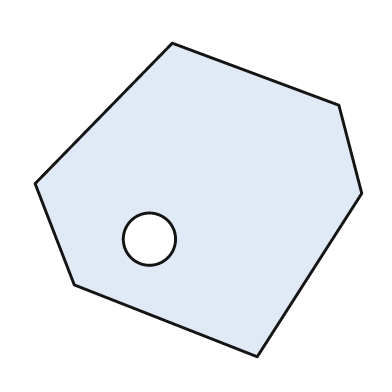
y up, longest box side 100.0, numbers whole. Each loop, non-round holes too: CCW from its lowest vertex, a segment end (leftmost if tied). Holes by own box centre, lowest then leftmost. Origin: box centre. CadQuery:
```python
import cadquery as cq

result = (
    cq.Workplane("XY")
    .moveTo(18.0, -48.0)
    .lineTo(50.0, 2.0)
    .lineTo(43.0, 29.0)
    .lineTo(-8.0, 48.0)
    .lineTo(-50.0, 5.0)
    .lineTo(-38.0, -26.0)
    .close()
    .moveTo(-15.0, -12.0)
    .circle(8.0)
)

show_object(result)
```